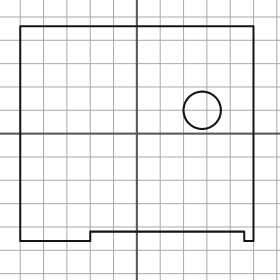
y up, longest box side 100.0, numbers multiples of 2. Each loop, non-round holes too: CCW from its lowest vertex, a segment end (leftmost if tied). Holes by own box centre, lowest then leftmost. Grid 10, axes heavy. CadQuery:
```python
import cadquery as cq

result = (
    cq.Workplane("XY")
    .moveTo(-50.0, -46.0)
    .lineTo(-20.0, -46.0)
    .lineTo(-20.0, -42.0)
    .lineTo(46.0, -42.0)
    .lineTo(46.0, -46.0)
    .lineTo(50.0, -46.0)
    .lineTo(50.0, 46.0)
    .lineTo(-50.0, 46.0)
    .close()
    .moveTo(28.0, 10.0)
    .circle(8.0)
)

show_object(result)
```